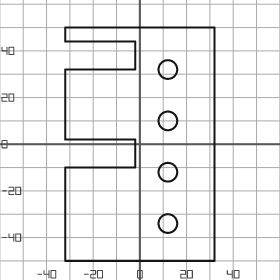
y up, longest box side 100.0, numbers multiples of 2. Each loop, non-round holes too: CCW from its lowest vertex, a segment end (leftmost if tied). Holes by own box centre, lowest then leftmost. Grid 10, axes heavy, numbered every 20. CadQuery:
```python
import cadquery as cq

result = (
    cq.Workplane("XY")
    .moveTo(-32.0, -50.0)
    .lineTo(32.0, -50.0)
    .lineTo(32.0, 50.0)
    .lineTo(-32.0, 50.0)
    .lineTo(-32.0, 44.0)
    .lineTo(-2.0, 44.0)
    .lineTo(-2.0, 32.0)
    .lineTo(-32.0, 32.0)
    .lineTo(-32.0, 2.0)
    .lineTo(-2.0, 2.0)
    .lineTo(-2.0, -10.0)
    .lineTo(-32.0, -10.0)
    .close()
    .moveTo(12.0, -34.0)
    .circle(4.0)
    .moveTo(12.0, -12.0)
    .circle(4.0)
    .moveTo(12.0, 10.0)
    .circle(4.0)
    .moveTo(12.0, 32.0)
    .circle(4.0)
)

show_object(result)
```